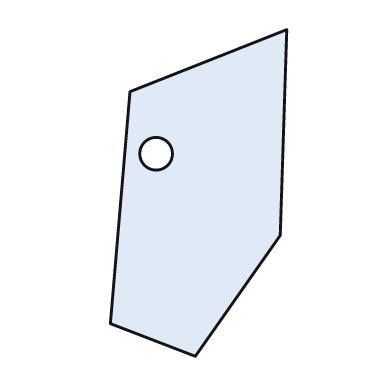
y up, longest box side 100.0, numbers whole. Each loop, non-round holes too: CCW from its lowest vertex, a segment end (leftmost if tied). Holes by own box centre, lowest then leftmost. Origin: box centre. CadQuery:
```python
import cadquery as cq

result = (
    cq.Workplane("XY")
    .moveTo(-1.0, -50.0)
    .lineTo(25.0, -13.0)
    .lineTo(27.0, 50.0)
    .lineTo(-21.0, 31.0)
    .lineTo(-27.0, -40.0)
    .close()
    .moveTo(-13.0, 12.0)
    .circle(5.0)
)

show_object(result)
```